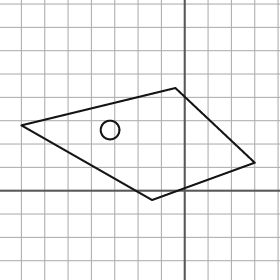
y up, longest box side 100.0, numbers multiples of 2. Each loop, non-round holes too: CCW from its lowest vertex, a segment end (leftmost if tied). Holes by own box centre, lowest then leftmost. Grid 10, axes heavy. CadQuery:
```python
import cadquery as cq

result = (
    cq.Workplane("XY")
    .moveTo(-14.0, -4.0)
    .lineTo(30.0, 12.0)
    .lineTo(-4.0, 44.0)
    .lineTo(-70.0, 28.0)
    .close()
    .moveTo(-32.0, 26.0)
    .circle(4.0)
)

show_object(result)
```